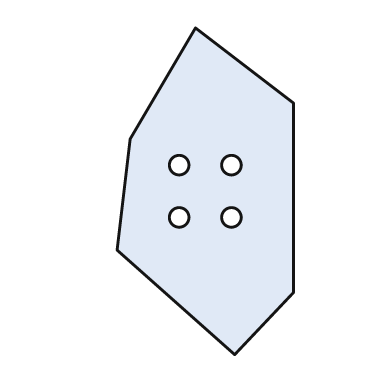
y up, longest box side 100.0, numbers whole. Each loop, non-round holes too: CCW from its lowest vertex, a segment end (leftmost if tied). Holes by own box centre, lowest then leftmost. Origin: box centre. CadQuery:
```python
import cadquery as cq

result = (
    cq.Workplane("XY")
    .moveTo(9.0, -50.0)
    .lineTo(27.0, -31.0)
    .lineTo(27.0, 27.0)
    .lineTo(-3.0, 50.0)
    .lineTo(-23.0, 16.0)
    .lineTo(-27.0, -18.0)
    .close()
    .moveTo(-8.0, -8.0)
    .circle(3.0)
    .moveTo(8.0, -8.0)
    .circle(3.0)
    .moveTo(-8.0, 8.0)
    .circle(3.0)
    .moveTo(8.0, 8.0)
    .circle(3.0)
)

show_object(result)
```